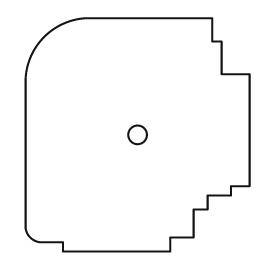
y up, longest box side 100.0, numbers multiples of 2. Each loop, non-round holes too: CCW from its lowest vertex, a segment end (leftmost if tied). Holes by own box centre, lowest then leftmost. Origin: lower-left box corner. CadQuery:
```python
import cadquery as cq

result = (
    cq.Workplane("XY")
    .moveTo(16.0, 0.0)
    .lineTo(62.0, 0.0)
    .lineTo(62.0, 6.0)
    .lineTo(72.0, 6.0)
    .lineTo(72.0, 18.0)
    .lineTo(78.0, 18.0)
    .lineTo(78.0, 24.0)
    .lineTo(88.0, 24.0)
    .lineTo(88.0, 28.0)
    .lineTo(96.0, 28.0)
    .lineTo(96.0, 76.0)
    .lineTo(84.0, 76.0)
    .lineTo(84.0, 90.0)
    .lineTo(80.0, 90.0)
    .lineTo(80.0, 100.0)
    .lineTo(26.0, 100.0)
    .threePointArc((8.0, 92.0), (0.0, 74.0))
    .lineTo(0.0, 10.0)
    .threePointArc((2.0, 6.0), (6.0, 4.0))
    .lineTo(16.0, 4.0)
    .close()
    .moveTo(48.0, 50.0)
    .circle(4.0)
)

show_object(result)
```